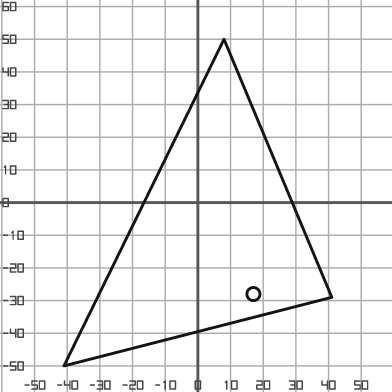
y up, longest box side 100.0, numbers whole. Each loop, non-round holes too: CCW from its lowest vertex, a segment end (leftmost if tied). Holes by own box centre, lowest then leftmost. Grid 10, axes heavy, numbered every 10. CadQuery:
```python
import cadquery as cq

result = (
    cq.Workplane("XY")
    .moveTo(-41.0, -50.0)
    .lineTo(41.0, -29.0)
    .lineTo(8.0, 50.0)
    .close()
    .moveTo(17.0, -28.0)
    .circle(2.0)
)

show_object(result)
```